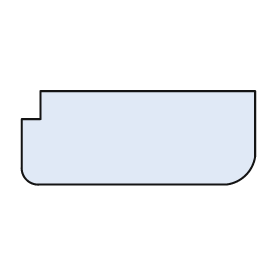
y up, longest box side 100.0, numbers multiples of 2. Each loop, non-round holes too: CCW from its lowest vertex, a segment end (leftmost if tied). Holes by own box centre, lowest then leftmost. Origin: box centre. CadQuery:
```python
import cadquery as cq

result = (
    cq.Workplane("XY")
    .moveTo(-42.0, -20.0)
    .lineTo(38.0, -20.0)
    .threePointArc((46.0, -16.0), (50.0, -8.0))
    .lineTo(50.0, 20.0)
    .lineTo(-42.0, 20.0)
    .lineTo(-42.0, 8.0)
    .lineTo(-50.0, 8.0)
    .lineTo(-50.0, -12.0)
    .threePointArc((-48.0, -18.0), (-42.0, -20.0))
    .close()
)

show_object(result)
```